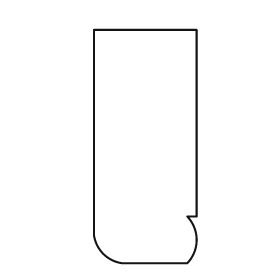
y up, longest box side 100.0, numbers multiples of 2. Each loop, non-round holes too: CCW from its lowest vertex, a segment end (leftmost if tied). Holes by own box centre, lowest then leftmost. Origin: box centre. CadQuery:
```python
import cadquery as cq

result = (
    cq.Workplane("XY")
    .moveTo(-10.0, -50.0)
    .lineTo(18.0, -50.0)
    .threePointArc((22.0, -40.0), (18.0, -30.0))
    .lineTo(22.0, -30.0)
    .lineTo(22.0, 50.0)
    .lineTo(-22.0, 50.0)
    .lineTo(-22.0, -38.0)
    .threePointArc((-18.0, -46.0), (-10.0, -50.0))
    .close()
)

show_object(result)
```